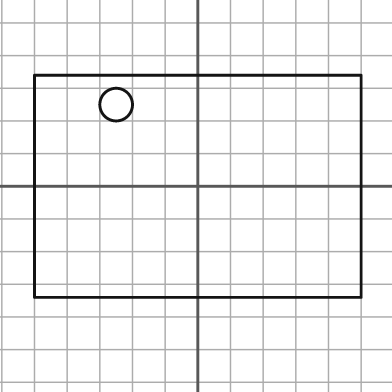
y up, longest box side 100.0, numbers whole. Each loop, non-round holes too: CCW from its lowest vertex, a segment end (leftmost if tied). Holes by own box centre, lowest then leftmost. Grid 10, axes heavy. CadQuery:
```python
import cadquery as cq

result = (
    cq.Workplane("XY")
    .moveTo(-50.0, -34.0)
    .lineTo(50.0, -34.0)
    .lineTo(50.0, 34.0)
    .lineTo(-50.0, 34.0)
    .close()
    .moveTo(-25.0, 25.0)
    .circle(5.0)
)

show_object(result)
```